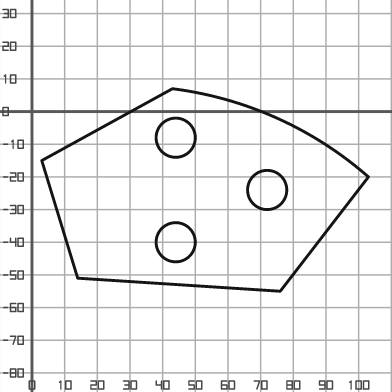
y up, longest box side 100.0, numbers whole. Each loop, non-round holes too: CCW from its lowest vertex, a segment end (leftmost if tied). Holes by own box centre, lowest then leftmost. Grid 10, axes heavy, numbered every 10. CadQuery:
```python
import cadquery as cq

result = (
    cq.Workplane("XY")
    .moveTo(76.0, -55.0)
    .lineTo(103.0, -20.0)
    .threePointArc((75.0, -2.0), (43.0, 7.0))
    .lineTo(3.0, -15.0)
    .lineTo(14.0, -51.0)
    .close()
    .moveTo(44.0, -40.0)
    .circle(6.0)
    .moveTo(72.0, -24.0)
    .circle(6.0)
    .moveTo(44.0, -8.0)
    .circle(6.0)
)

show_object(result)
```